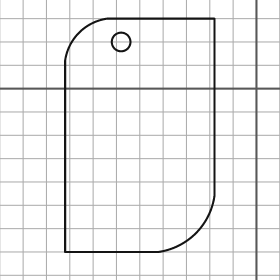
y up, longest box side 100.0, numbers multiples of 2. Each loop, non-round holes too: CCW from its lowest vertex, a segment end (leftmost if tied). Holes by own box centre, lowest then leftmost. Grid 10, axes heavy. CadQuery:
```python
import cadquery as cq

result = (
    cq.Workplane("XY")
    .moveTo(-82.0, -70.0)
    .lineTo(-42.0, -70.0)
    .threePointArc((-26.0, -62.0), (-18.0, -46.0))
    .lineTo(-18.0, 30.0)
    .lineTo(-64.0, 30.0)
    .threePointArc((-76.0, 24.0), (-82.0, 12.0))
    .close()
    .moveTo(-58.0, 20.0)
    .circle(4.0)
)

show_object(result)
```